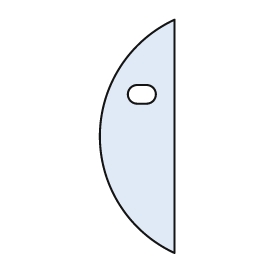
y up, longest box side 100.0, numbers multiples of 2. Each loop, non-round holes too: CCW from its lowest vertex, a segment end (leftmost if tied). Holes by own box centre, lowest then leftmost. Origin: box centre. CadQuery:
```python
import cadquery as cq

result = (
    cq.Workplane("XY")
    .moveTo(16.0, -50.0)
    .lineTo(16.0, 50.0)
    .threePointArc((-16.0, 0.0), (16.0, -50.0))
    .close()
    .moveTo(0.0, 14.0)
    .lineTo(4.0, 14.0)
    .threePointArc((8.0, 18.0), (4.0, 22.0))
    .lineTo(0.0, 22.0)
    .threePointArc((-4.0, 18.0), (0.0, 14.0))
    .close()
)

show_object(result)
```